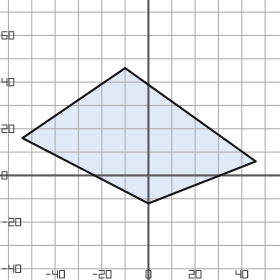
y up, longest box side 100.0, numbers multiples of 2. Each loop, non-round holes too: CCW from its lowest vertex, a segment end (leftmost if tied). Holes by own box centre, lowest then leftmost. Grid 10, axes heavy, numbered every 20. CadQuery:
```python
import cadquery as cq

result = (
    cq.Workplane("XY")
    .moveTo(0.0, -12.0)
    .lineTo(46.0, 6.0)
    .lineTo(-10.0, 46.0)
    .lineTo(-54.0, 16.0)
    .close()
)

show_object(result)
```